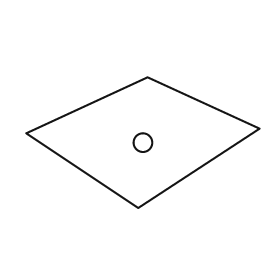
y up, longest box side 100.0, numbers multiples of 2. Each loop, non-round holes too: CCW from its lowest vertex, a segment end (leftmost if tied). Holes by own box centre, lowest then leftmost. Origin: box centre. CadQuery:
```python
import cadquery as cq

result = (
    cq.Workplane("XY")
    .moveTo(-2.0, -28.0)
    .lineTo(50.0, 6.0)
    .lineTo(2.0, 28.0)
    .lineTo(-50.0, 4.0)
    .close()
    .moveTo(0.0, 0.0)
    .circle(4.0)
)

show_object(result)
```